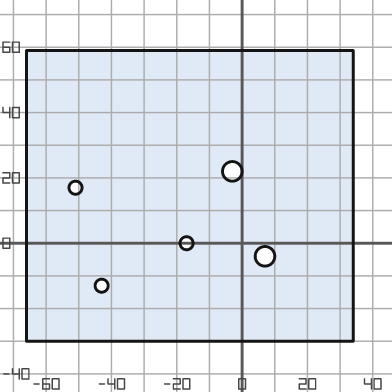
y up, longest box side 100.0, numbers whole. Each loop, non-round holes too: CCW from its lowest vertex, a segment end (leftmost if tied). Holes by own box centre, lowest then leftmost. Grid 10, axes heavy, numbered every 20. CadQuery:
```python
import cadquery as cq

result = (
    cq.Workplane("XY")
    .moveTo(-66.0, -30.0)
    .lineTo(34.0, -30.0)
    .lineTo(34.0, 59.0)
    .lineTo(-66.0, 59.0)
    .close()
    .moveTo(-43.0, -13.0)
    .circle(2.0)
    .moveTo(7.0, -4.0)
    .circle(3.0)
    .moveTo(-17.0, 0.0)
    .circle(2.0)
    .moveTo(-51.0, 17.0)
    .circle(2.0)
    .moveTo(-3.0, 22.0)
    .circle(3.0)
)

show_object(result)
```